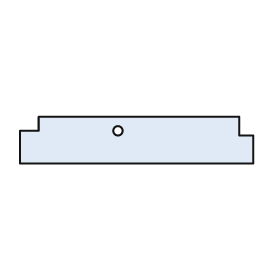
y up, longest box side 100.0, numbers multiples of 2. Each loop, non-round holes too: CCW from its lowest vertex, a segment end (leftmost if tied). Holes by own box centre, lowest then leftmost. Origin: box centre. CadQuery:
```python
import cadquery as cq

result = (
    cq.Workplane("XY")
    .moveTo(-50.0, -10.0)
    .lineTo(50.0, -10.0)
    .lineTo(50.0, 2.0)
    .lineTo(44.0, 2.0)
    .lineTo(44.0, 10.0)
    .lineTo(-42.0, 10.0)
    .lineTo(-42.0, 4.0)
    .lineTo(-50.0, 4.0)
    .close()
    .moveTo(-8.0, 4.0)
    .circle(2.0)
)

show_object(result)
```